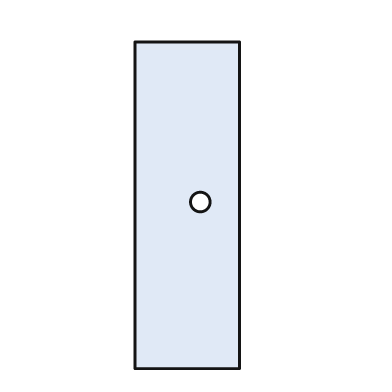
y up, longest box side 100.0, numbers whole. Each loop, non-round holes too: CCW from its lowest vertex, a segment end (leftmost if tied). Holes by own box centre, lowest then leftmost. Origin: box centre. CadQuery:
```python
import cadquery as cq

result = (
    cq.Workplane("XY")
    .moveTo(-16.0, -50.0)
    .lineTo(16.0, -50.0)
    .lineTo(16.0, 50.0)
    .lineTo(-16.0, 50.0)
    .close()
    .moveTo(4.0, 1.0)
    .circle(3.0)
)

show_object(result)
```